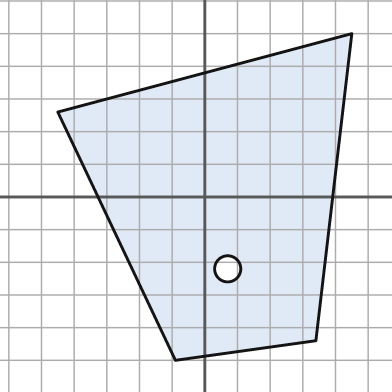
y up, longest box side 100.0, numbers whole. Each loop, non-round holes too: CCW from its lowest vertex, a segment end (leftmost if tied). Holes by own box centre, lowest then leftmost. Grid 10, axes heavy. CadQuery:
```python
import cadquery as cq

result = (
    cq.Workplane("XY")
    .moveTo(-9.0, -50.0)
    .lineTo(34.0, -44.0)
    .lineTo(45.0, 50.0)
    .lineTo(-45.0, 26.0)
    .close()
    .moveTo(7.0, -22.0)
    .circle(4.0)
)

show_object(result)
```